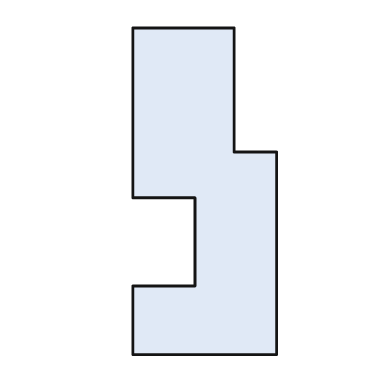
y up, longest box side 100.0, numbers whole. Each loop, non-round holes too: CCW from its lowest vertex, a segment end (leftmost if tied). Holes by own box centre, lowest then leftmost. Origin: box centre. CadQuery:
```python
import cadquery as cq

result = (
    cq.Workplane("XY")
    .moveTo(-22.0, -50.0)
    .lineTo(22.0, -50.0)
    .lineTo(22.0, 12.0)
    .lineTo(9.0, 12.0)
    .lineTo(9.0, 50.0)
    .lineTo(-22.0, 50.0)
    .lineTo(-22.0, -2.0)
    .lineTo(-3.0, -2.0)
    .lineTo(-3.0, -29.0)
    .lineTo(-22.0, -29.0)
    .close()
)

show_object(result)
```